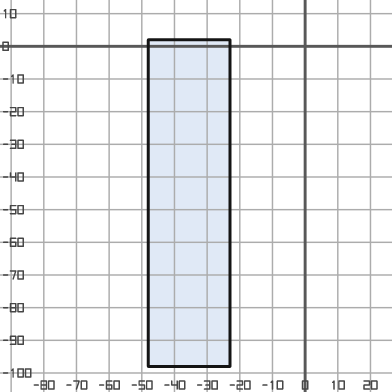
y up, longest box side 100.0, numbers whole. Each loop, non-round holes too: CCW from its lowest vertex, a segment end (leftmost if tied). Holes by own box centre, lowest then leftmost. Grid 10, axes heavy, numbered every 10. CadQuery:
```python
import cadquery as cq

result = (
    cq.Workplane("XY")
    .moveTo(-48.0, -98.0)
    .lineTo(-23.0, -98.0)
    .lineTo(-23.0, 2.0)
    .lineTo(-48.0, 2.0)
    .close()
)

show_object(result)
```